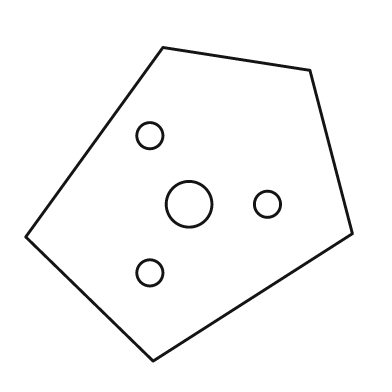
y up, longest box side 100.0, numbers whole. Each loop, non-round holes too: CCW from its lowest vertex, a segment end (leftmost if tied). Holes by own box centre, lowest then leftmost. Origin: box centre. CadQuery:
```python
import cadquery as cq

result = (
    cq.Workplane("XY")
    .moveTo(-11.0, -48.0)
    .lineTo(50.0, -9.0)
    .lineTo(37.0, 41.0)
    .lineTo(-8.0, 48.0)
    .lineTo(-50.0, -10.0)
    .close()
    .moveTo(-12.0, -21.0)
    .circle(4.0)
    .moveTo(0.0, 0.0)
    .circle(7.0)
    .moveTo(24.0, 0.0)
    .circle(4.0)
    .moveTo(-12.0, 21.0)
    .circle(4.0)
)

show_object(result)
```